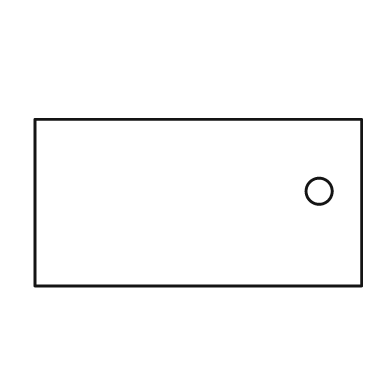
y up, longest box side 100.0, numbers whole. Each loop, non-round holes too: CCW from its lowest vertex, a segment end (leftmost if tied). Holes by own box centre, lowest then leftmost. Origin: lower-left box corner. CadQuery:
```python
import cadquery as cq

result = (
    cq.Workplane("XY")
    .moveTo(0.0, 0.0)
    .lineTo(100.0, 0.0)
    .lineTo(100.0, 51.0)
    .lineTo(0.0, 51.0)
    .close()
    .moveTo(87.0, 29.0)
    .circle(4.0)
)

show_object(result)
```